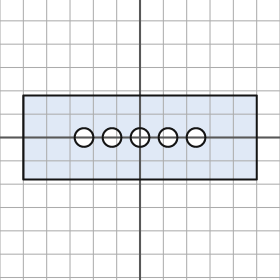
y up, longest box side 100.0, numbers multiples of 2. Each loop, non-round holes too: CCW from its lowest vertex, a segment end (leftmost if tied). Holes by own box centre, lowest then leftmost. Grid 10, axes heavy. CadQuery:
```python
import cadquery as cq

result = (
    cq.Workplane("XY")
    .moveTo(-50.0, -18.0)
    .lineTo(50.0, -18.0)
    .lineTo(50.0, 18.0)
    .lineTo(-50.0, 18.0)
    .close()
    .moveTo(-24.0, 0.0)
    .circle(4.0)
    .moveTo(-12.0, 0.0)
    .circle(4.0)
    .moveTo(0.0, 0.0)
    .circle(4.0)
    .moveTo(12.0, 0.0)
    .circle(4.0)
    .moveTo(24.0, 0.0)
    .circle(4.0)
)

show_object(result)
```